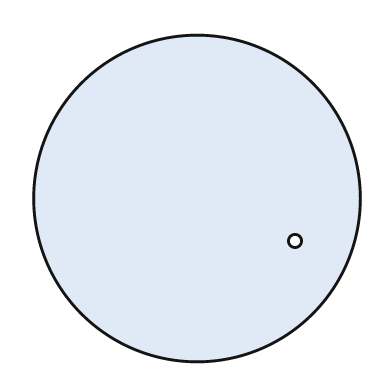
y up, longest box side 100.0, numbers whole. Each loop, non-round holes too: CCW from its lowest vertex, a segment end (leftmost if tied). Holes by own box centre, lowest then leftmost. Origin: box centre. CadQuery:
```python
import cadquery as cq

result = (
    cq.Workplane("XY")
    .moveTo(0.0, 0.0)
    .circle(50.0)
    .moveTo(30.0, -13.0)
    .circle(2.0)
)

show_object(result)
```